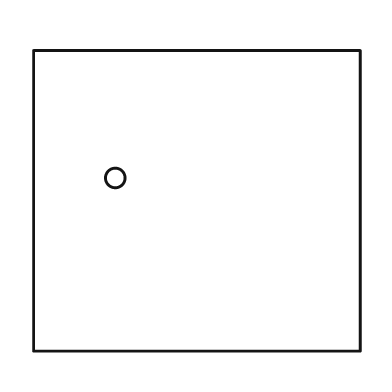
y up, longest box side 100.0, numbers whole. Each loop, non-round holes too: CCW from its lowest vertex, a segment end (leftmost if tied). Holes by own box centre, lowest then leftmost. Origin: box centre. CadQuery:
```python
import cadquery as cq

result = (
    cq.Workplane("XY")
    .moveTo(-50.0, -46.0)
    .lineTo(50.0, -46.0)
    .lineTo(50.0, 46.0)
    .lineTo(-50.0, 46.0)
    .close()
    .moveTo(-25.0, 7.0)
    .circle(3.0)
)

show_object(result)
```